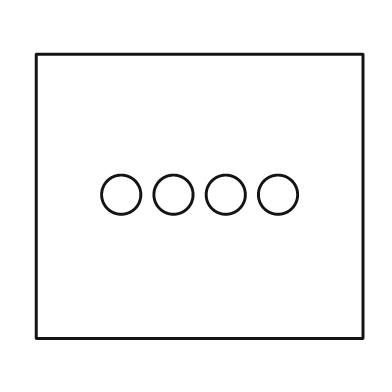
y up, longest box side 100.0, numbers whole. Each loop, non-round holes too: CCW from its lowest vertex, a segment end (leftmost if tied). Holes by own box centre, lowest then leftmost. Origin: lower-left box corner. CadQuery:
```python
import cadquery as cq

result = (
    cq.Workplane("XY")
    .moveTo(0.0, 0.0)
    .lineTo(100.0, 0.0)
    .lineTo(100.0, 87.0)
    .lineTo(0.0, 87.0)
    .close()
    .moveTo(26.0, 44.0)
    .circle(6.0)
    .moveTo(42.0, 44.0)
    .circle(6.0)
    .moveTo(58.0, 44.0)
    .circle(6.0)
    .moveTo(74.0, 44.0)
    .circle(6.0)
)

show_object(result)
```